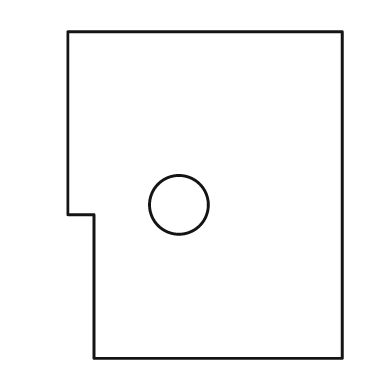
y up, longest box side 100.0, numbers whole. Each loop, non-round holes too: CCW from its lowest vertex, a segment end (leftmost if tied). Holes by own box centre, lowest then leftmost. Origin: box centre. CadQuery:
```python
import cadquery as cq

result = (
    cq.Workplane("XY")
    .moveTo(-34.0, -50.0)
    .lineTo(42.0, -50.0)
    .lineTo(42.0, 50.0)
    .lineTo(-42.0, 50.0)
    .lineTo(-42.0, -6.0)
    .lineTo(-34.0, -6.0)
    .close()
    .moveTo(-8.0, -3.0)
    .circle(9.0)
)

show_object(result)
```